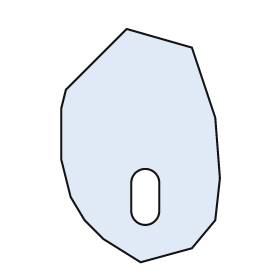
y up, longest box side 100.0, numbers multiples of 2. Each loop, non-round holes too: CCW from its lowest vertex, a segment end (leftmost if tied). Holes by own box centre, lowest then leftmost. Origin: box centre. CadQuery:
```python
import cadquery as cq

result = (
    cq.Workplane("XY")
    .moveTo(0.0, -50.0)
    .lineTo(22.0, -44.0)
    .lineTo(32.0, -32.0)
    .lineTo(34.0, -14.0)
    .lineTo(32.0, 12.0)
    .lineTo(22.0, 42.0)
    .lineTo(-6.0, 50.0)
    .lineTo(-32.0, 24.0)
    .lineTo(-34.0, 16.0)
    .lineTo(-34.0, -6.0)
    .lineTo(-30.0, -22.0)
    .lineTo(-24.0, -32.0)
    .lineTo(-16.0, -40.0)
    .close()
    .moveTo(-4.0, -28.0)
    .threePointArc((2.0, -34.0), (8.0, -28.0))
    .lineTo(8.0, -16.0)
    .threePointArc((2.0, -10.0), (-4.0, -16.0))
    .close()
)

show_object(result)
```